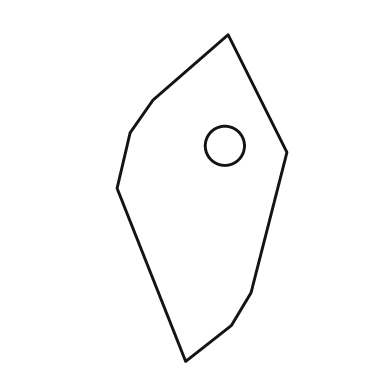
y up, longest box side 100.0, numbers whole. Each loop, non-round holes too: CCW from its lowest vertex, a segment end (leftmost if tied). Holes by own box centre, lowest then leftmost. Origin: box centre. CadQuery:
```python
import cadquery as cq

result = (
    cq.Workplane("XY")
    .moveTo(-5.0, -50.0)
    .lineTo(9.0, -39.0)
    .lineTo(15.0, -29.0)
    .lineTo(26.0, 14.0)
    .lineTo(8.0, 50.0)
    .lineTo(-15.0, 30.0)
    .lineTo(-22.0, 20.0)
    .lineTo(-26.0, 3.0)
    .close()
    .moveTo(7.0, 16.0)
    .circle(6.0)
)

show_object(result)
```